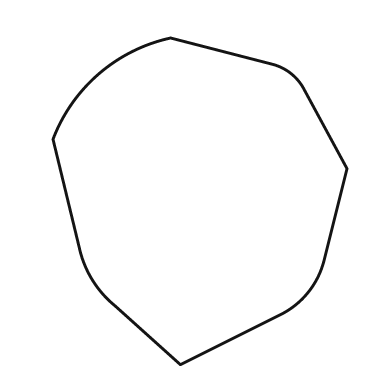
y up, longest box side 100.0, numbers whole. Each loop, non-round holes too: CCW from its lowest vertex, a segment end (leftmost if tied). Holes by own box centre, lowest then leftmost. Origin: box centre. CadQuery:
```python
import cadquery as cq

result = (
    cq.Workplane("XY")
    .moveTo(-6.0, -50.0)
    .lineTo(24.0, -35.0)
    .threePointArc((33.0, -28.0), (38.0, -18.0))
    .lineTo(45.0, 10.0)
    .lineTo(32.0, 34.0)
    .threePointArc((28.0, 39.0), (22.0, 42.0))
    .lineTo(-9.0, 50.0)
    .threePointArc((-31.0, 39.0), (-45.0, 19.0))
    .lineTo(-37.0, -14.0)
    .threePointArc((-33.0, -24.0), (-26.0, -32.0))
    .close()
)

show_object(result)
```